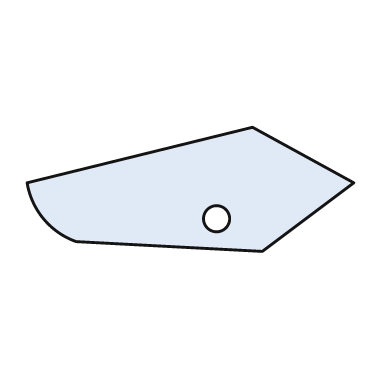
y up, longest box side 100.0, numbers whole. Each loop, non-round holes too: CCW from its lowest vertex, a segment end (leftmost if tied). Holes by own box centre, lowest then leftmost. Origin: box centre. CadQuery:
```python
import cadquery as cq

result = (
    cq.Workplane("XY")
    .moveTo(22.0, -19.0)
    .lineTo(50.0, 2.0)
    .lineTo(19.0, 19.0)
    .lineTo(-50.0, 2.0)
    .threePointArc((-45.0, -9.0), (-35.0, -16.0))
    .close()
    .moveTo(8.0, -9.0)
    .circle(4.0)
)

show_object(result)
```